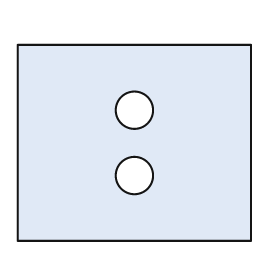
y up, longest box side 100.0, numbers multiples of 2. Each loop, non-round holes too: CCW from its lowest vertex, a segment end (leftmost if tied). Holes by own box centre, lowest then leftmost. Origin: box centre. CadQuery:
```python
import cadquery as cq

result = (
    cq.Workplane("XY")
    .moveTo(-50.0, -42.0)
    .lineTo(50.0, -42.0)
    .lineTo(50.0, 42.0)
    .lineTo(-50.0, 42.0)
    .close()
    .moveTo(0.0, -14.0)
    .circle(8.0)
    .moveTo(0.0, 14.0)
    .circle(8.0)
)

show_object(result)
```